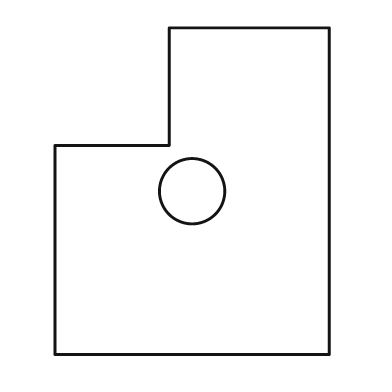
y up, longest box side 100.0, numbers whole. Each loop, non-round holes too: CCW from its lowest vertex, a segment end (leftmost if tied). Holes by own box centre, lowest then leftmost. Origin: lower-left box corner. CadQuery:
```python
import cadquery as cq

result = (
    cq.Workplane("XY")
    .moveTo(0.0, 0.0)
    .lineTo(84.0, 0.0)
    .lineTo(84.0, 100.0)
    .lineTo(35.0, 100.0)
    .lineTo(35.0, 64.0)
    .lineTo(0.0, 64.0)
    .close()
    .moveTo(42.0, 50.0)
    .circle(10.0)
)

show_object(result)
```